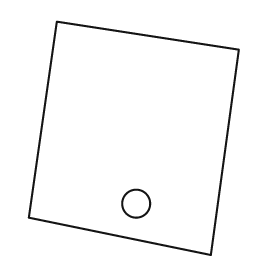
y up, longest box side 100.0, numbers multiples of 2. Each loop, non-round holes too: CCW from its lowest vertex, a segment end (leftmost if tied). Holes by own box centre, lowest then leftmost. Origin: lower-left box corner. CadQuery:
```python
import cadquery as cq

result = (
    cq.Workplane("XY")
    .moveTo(78.0, 0.0)
    .lineTo(90.0, 88.0)
    .lineTo(12.0, 100.0)
    .lineTo(0.0, 16.0)
    .close()
    .moveTo(46.0, 22.0)
    .circle(6.0)
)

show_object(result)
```